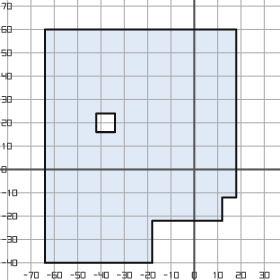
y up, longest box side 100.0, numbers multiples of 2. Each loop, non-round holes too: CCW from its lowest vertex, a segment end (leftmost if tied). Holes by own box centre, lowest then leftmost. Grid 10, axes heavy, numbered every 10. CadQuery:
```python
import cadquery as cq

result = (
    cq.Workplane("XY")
    .moveTo(-64.0, -40.0)
    .lineTo(-18.0, -40.0)
    .lineTo(-18.0, -22.0)
    .lineTo(12.0, -22.0)
    .lineTo(12.0, -12.0)
    .lineTo(18.0, -12.0)
    .lineTo(18.0, 60.0)
    .lineTo(-64.0, 60.0)
    .close()
    .moveTo(-42.0, 16.0)
    .lineTo(-34.0, 16.0)
    .lineTo(-34.0, 24.0)
    .lineTo(-42.0, 24.0)
    .close()
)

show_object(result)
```